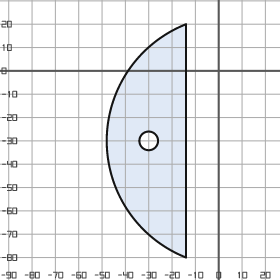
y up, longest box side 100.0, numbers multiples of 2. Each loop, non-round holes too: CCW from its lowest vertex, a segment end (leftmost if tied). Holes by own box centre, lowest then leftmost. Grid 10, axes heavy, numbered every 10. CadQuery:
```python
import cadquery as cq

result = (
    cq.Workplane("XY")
    .moveTo(-14.0, -80.0)
    .lineTo(-14.0, 20.0)
    .threePointArc((-48.0, -30.0), (-14.0, -80.0))
    .close()
    .moveTo(-30.0, -30.0)
    .circle(4.0)
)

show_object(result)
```